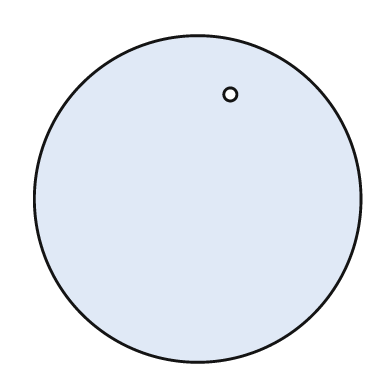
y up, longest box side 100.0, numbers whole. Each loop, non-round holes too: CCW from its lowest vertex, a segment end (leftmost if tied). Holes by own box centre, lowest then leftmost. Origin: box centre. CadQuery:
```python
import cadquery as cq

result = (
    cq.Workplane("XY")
    .moveTo(0.0, 0.0)
    .circle(50.0)
    .moveTo(10.0, 32.0)
    .circle(2.0)
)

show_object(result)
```